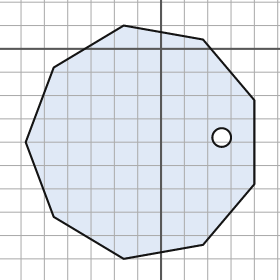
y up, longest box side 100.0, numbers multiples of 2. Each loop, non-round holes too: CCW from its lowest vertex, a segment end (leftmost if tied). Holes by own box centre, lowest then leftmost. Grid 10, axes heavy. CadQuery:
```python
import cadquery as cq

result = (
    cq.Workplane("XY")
    .moveTo(-16.0, -90.0)
    .lineTo(18.0, -84.0)
    .lineTo(40.0, -58.0)
    .lineTo(40.0, -22.0)
    .lineTo(18.0, 4.0)
    .lineTo(-16.0, 10.0)
    .lineTo(-46.0, -8.0)
    .lineTo(-58.0, -40.0)
    .lineTo(-46.0, -72.0)
    .close()
    .moveTo(26.0, -38.0)
    .circle(4.0)
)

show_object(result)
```